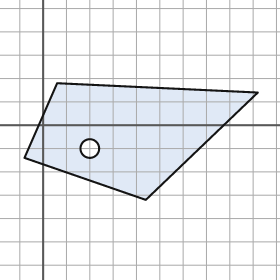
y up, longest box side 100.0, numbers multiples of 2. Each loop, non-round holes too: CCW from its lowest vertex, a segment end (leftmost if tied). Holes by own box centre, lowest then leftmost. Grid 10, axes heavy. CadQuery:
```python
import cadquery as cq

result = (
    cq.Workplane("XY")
    .moveTo(44.0, -32.0)
    .lineTo(92.0, 14.0)
    .lineTo(6.0, 18.0)
    .lineTo(-8.0, -14.0)
    .close()
    .moveTo(20.0, -10.0)
    .circle(4.0)
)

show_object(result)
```